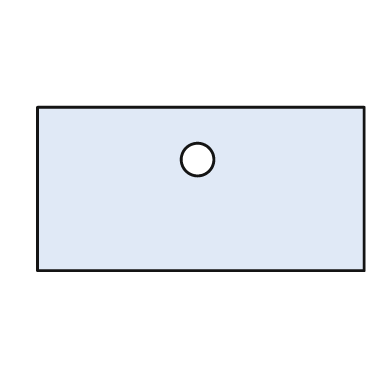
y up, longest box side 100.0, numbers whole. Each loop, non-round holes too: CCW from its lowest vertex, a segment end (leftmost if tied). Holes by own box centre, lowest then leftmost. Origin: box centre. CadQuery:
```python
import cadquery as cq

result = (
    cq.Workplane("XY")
    .moveTo(-50.0, -25.0)
    .lineTo(50.0, -25.0)
    .lineTo(50.0, 25.0)
    .lineTo(-50.0, 25.0)
    .close()
    .moveTo(-1.0, 9.0)
    .circle(5.0)
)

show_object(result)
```